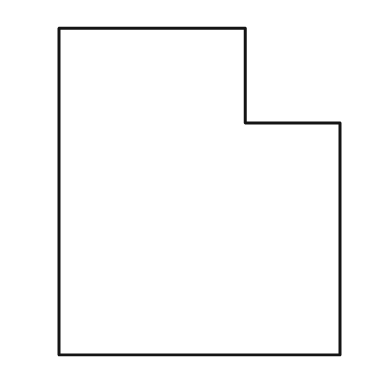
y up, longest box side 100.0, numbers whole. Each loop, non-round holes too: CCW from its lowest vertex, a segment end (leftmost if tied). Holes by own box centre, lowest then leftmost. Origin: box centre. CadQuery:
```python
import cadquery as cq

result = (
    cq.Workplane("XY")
    .moveTo(-43.0, -50.0)
    .lineTo(43.0, -50.0)
    .lineTo(43.0, 21.0)
    .lineTo(14.0, 21.0)
    .lineTo(14.0, 50.0)
    .lineTo(-43.0, 50.0)
    .close()
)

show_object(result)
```